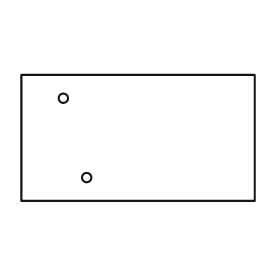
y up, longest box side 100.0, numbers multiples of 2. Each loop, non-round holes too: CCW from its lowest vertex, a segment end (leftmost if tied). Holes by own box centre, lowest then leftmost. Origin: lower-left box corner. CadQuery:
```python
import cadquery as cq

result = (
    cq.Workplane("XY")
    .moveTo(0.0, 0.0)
    .lineTo(100.0, 0.0)
    .lineTo(100.0, 54.0)
    .lineTo(0.0, 54.0)
    .close()
    .moveTo(28.0, 10.0)
    .circle(2.0)
    .moveTo(18.0, 44.0)
    .circle(2.0)
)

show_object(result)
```